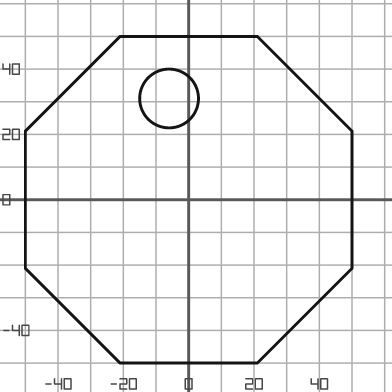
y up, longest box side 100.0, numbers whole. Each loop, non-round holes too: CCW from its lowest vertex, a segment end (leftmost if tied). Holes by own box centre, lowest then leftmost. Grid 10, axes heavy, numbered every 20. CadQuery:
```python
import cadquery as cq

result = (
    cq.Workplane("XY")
    .moveTo(-21.0, -50.0)
    .lineTo(21.0, -50.0)
    .lineTo(50.0, -21.0)
    .lineTo(50.0, 21.0)
    .lineTo(21.0, 50.0)
    .lineTo(-21.0, 50.0)
    .lineTo(-50.0, 21.0)
    .lineTo(-50.0, -21.0)
    .close()
    .moveTo(-6.0, 31.0)
    .circle(9.0)
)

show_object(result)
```